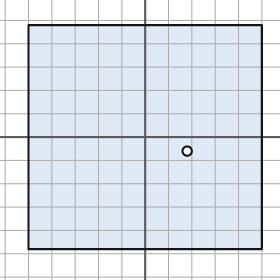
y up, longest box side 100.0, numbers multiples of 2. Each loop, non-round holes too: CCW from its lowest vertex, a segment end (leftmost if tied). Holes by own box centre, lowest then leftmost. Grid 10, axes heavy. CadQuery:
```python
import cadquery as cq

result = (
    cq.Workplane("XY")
    .moveTo(-50.0, -48.0)
    .lineTo(50.0, -48.0)
    .lineTo(50.0, 48.0)
    .lineTo(-50.0, 48.0)
    .close()
    .moveTo(18.0, -6.0)
    .circle(2.0)
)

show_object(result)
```